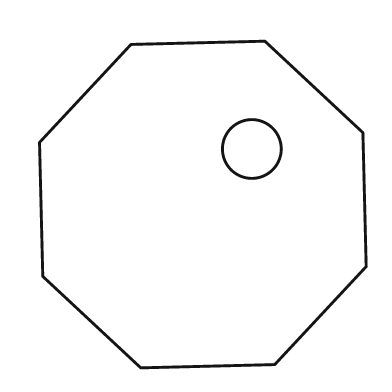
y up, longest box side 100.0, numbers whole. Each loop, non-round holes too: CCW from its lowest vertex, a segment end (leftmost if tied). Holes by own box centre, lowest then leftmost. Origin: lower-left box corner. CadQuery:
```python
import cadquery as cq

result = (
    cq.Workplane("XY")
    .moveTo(31.0, 0.0)
    .lineTo(72.0, 1.0)
    .lineTo(100.0, 31.0)
    .lineTo(99.0, 72.0)
    .lineTo(69.0, 100.0)
    .lineTo(28.0, 99.0)
    .lineTo(0.0, 69.0)
    .lineTo(1.0, 28.0)
    .close()
    .moveTo(65.0, 67.0)
    .circle(9.0)
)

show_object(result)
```